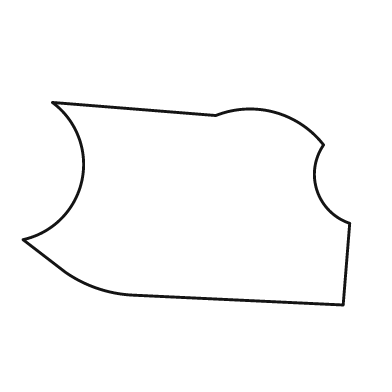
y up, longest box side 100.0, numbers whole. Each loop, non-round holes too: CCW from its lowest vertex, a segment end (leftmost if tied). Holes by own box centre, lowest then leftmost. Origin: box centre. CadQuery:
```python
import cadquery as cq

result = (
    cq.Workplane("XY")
    .moveTo(48.0, -31.0)
    .lineTo(50.0, -6.0)
    .threePointArc((40.0, 4.0), (42.0, 18.0))
    .threePointArc((27.0, 28.0), (9.0, 27.0))
    .lineTo(-41.0, 31.0)
    .threePointArc((-32.0, 7.0), (-50.0, -11.0))
    .lineTo(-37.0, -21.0)
    .threePointArc((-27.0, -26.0), (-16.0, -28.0))
    .close()
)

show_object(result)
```